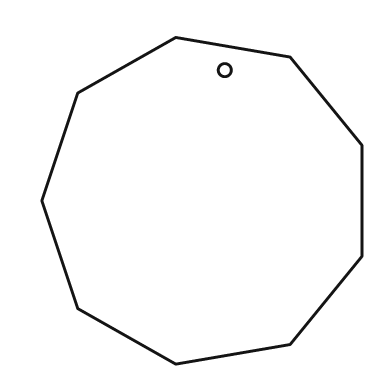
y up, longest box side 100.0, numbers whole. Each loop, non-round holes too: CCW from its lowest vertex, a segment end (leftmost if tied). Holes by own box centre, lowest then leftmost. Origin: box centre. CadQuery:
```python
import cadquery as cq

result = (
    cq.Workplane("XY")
    .moveTo(-8.0, -50.0)
    .lineTo(27.0, -44.0)
    .lineTo(49.0, -17.0)
    .lineTo(49.0, 17.0)
    .lineTo(27.0, 44.0)
    .lineTo(-8.0, 50.0)
    .lineTo(-38.0, 33.0)
    .lineTo(-49.0, 0.0)
    .lineTo(-38.0, -33.0)
    .close()
    .moveTo(7.0, 40.0)
    .circle(2.0)
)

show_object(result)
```